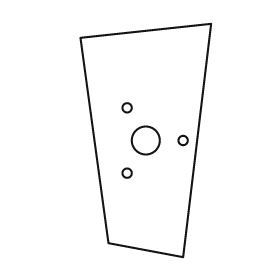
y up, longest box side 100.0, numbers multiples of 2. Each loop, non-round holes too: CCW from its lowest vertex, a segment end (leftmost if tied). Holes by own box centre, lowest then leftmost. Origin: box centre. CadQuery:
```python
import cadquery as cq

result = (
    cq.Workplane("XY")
    .moveTo(16.0, -50.0)
    .lineTo(28.0, 50.0)
    .lineTo(-28.0, 44.0)
    .lineTo(-16.0, -44.0)
    .close()
    .moveTo(-8.0, -14.0)
    .circle(2.0)
    .moveTo(0.0, 0.0)
    .circle(6.0)
    .moveTo(16.0, 0.0)
    .circle(2.0)
    .moveTo(-8.0, 14.0)
    .circle(2.0)
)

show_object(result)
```